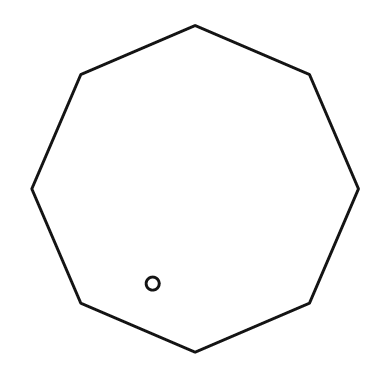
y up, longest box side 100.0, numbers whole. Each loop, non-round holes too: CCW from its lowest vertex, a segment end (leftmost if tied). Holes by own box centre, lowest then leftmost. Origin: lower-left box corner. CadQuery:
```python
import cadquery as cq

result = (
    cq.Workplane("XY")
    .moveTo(50.0, 0.0)
    .lineTo(85.0, 15.0)
    .lineTo(100.0, 50.0)
    .lineTo(85.0, 85.0)
    .lineTo(50.0, 100.0)
    .lineTo(15.0, 85.0)
    .lineTo(0.0, 50.0)
    .lineTo(15.0, 15.0)
    .close()
    .moveTo(37.0, 21.0)
    .circle(2.0)
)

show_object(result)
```